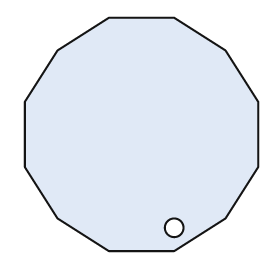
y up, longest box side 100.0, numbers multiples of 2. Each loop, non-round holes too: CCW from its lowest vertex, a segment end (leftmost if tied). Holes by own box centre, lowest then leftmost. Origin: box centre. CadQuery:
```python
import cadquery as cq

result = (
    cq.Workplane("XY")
    .moveTo(-14.0, -50.0)
    .lineTo(14.0, -50.0)
    .lineTo(36.0, -36.0)
    .lineTo(50.0, -14.0)
    .lineTo(50.0, 14.0)
    .lineTo(36.0, 36.0)
    .lineTo(14.0, 50.0)
    .lineTo(-14.0, 50.0)
    .lineTo(-36.0, 36.0)
    .lineTo(-50.0, 14.0)
    .lineTo(-50.0, -14.0)
    .lineTo(-36.0, -36.0)
    .close()
    .moveTo(14.0, -40.0)
    .circle(4.0)
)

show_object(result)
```